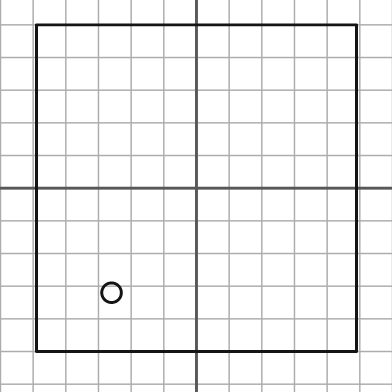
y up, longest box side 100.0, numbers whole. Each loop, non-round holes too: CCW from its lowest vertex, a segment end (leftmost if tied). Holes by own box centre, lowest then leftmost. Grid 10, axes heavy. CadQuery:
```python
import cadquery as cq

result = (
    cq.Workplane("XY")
    .moveTo(-49.0, -50.0)
    .lineTo(49.0, -50.0)
    .lineTo(49.0, 50.0)
    .lineTo(-49.0, 50.0)
    .close()
    .moveTo(-26.0, -32.0)
    .circle(3.0)
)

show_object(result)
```